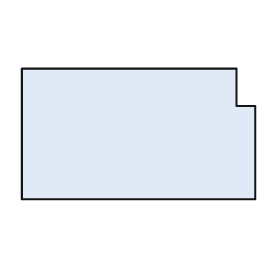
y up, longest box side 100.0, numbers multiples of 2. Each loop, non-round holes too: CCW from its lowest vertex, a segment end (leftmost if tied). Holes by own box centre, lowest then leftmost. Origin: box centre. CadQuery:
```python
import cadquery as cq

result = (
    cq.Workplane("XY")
    .moveTo(-50.0, -28.0)
    .lineTo(50.0, -28.0)
    .lineTo(50.0, 12.0)
    .lineTo(42.0, 12.0)
    .lineTo(42.0, 28.0)
    .lineTo(-50.0, 28.0)
    .close()
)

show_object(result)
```